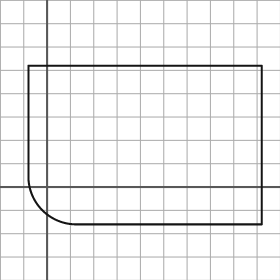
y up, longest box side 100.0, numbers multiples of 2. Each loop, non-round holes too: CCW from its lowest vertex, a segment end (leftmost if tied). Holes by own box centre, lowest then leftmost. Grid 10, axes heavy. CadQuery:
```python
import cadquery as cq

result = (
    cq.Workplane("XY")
    .moveTo(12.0, -16.0)
    .lineTo(92.0, -16.0)
    .lineTo(92.0, 52.0)
    .lineTo(-8.0, 52.0)
    .lineTo(-8.0, 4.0)
    .threePointArc((-2.0, -10.0), (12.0, -16.0))
    .close()
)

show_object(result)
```